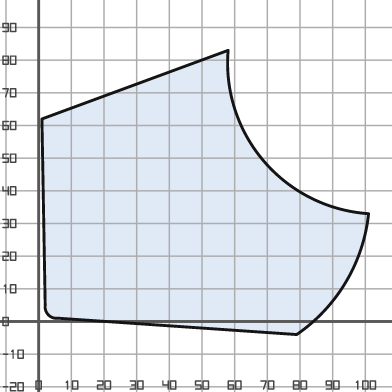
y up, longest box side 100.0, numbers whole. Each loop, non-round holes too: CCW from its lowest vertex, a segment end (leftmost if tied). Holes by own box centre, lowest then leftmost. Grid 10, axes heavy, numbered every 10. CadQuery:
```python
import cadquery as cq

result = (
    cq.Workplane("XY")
    .moveTo(79.0, -4.0)
    .threePointArc((94.0, 12.0), (101.0, 33.0))
    .threePointArc((69.0, 49.0), (58.0, 83.0))
    .lineTo(1.0, 62.0)
    .lineTo(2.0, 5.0)
    .threePointArc((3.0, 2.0), (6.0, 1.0))
    .close()
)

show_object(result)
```